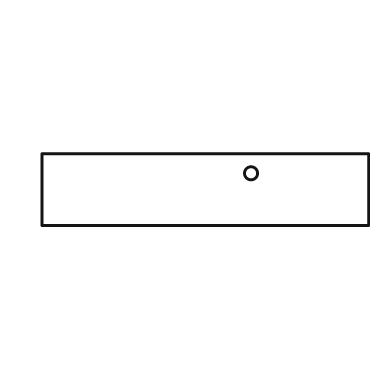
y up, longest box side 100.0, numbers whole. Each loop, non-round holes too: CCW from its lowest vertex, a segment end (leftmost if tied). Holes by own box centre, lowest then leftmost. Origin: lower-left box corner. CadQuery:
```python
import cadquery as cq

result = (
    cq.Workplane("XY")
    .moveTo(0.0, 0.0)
    .lineTo(100.0, 0.0)
    .lineTo(100.0, 22.0)
    .lineTo(0.0, 22.0)
    .close()
    .moveTo(64.0, 16.0)
    .circle(2.0)
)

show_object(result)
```